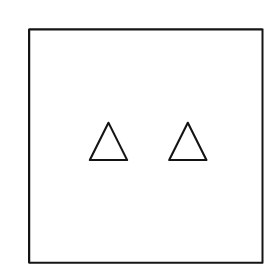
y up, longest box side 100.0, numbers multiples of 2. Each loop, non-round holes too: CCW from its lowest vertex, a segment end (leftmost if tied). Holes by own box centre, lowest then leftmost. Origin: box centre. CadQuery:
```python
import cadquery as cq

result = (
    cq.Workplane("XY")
    .moveTo(-50.0, -50.0)
    .lineTo(50.0, -50.0)
    .lineTo(50.0, 50.0)
    .lineTo(-50.0, 50.0)
    .close()
    .moveTo(-24.0, -6.0)
    .lineTo(-8.0, -6.0)
    .lineTo(-16.0, 10.0)
    .close()
    .moveTo(10.0, -6.0)
    .lineTo(26.0, -6.0)
    .lineTo(18.0, 10.0)
    .close()
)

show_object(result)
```